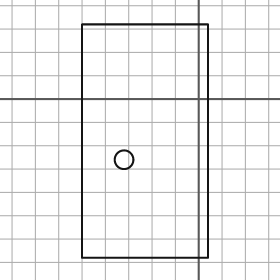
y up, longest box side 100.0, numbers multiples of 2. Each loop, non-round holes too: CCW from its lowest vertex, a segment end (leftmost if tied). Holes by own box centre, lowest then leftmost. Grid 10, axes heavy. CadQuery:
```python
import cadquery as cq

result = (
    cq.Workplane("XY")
    .moveTo(-50.0, -68.0)
    .lineTo(4.0, -68.0)
    .lineTo(4.0, 32.0)
    .lineTo(-50.0, 32.0)
    .close()
    .moveTo(-32.0, -26.0)
    .circle(4.0)
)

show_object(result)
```